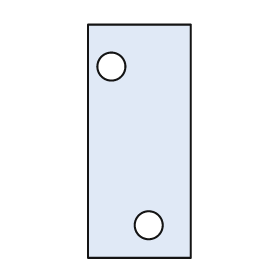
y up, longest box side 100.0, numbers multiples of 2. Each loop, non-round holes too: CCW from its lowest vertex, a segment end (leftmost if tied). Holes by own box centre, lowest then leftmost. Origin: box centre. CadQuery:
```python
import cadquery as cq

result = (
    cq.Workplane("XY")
    .moveTo(-22.0, -50.0)
    .lineTo(22.0, -50.0)
    .lineTo(22.0, 50.0)
    .lineTo(-22.0, 50.0)
    .close()
    .moveTo(4.0, -36.0)
    .circle(6.0)
    .moveTo(-12.0, 32.0)
    .circle(6.0)
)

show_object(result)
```